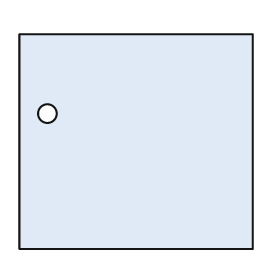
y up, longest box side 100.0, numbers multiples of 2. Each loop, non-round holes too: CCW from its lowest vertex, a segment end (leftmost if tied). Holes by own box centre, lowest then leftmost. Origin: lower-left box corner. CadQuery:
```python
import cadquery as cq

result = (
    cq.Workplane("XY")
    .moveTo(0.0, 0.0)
    .lineTo(100.0, 0.0)
    .lineTo(100.0, 92.0)
    .lineTo(0.0, 92.0)
    .close()
    .moveTo(12.0, 58.0)
    .circle(4.0)
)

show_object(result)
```